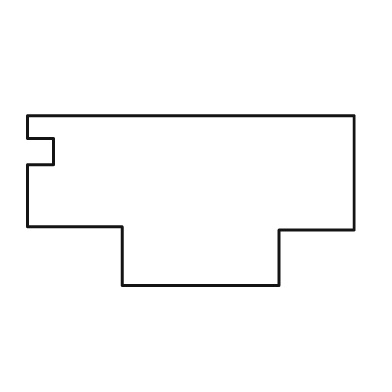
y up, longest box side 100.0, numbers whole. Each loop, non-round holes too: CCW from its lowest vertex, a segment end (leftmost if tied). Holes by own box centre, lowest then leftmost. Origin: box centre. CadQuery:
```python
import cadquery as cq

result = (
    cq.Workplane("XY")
    .moveTo(-21.0, -26.0)
    .lineTo(27.0, -26.0)
    .lineTo(27.0, -9.0)
    .lineTo(50.0, -9.0)
    .lineTo(50.0, 26.0)
    .lineTo(-50.0, 26.0)
    .lineTo(-50.0, 19.0)
    .lineTo(-42.0, 19.0)
    .lineTo(-42.0, 11.0)
    .lineTo(-50.0, 11.0)
    .lineTo(-50.0, -8.0)
    .lineTo(-21.0, -8.0)
    .close()
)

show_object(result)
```